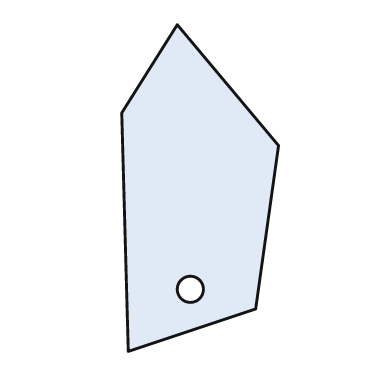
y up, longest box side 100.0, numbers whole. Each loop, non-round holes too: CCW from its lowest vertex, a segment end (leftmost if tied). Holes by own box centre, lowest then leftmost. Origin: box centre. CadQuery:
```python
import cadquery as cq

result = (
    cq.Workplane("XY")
    .moveTo(-22.0, -50.0)
    .lineTo(17.0, -37.0)
    .lineTo(24.0, 13.0)
    .lineTo(-7.0, 50.0)
    .lineTo(-24.0, 23.0)
    .close()
    .moveTo(-3.0, -31.0)
    .circle(4.0)
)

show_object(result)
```